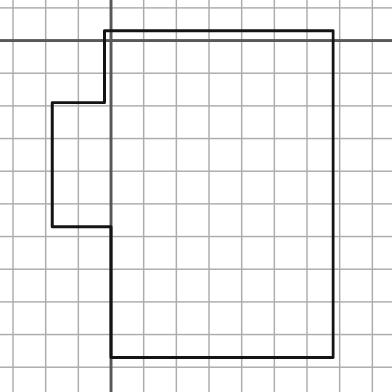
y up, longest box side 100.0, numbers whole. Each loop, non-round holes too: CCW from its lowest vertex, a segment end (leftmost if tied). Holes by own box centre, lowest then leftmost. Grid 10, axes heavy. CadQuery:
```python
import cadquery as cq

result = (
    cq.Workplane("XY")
    .moveTo(0.0, -97.0)
    .lineTo(68.0, -97.0)
    .lineTo(68.0, 3.0)
    .lineTo(-2.0, 3.0)
    .lineTo(-2.0, -19.0)
    .lineTo(-18.0, -19.0)
    .lineTo(-18.0, -57.0)
    .lineTo(0.0, -57.0)
    .close()
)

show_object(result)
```